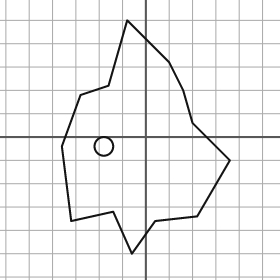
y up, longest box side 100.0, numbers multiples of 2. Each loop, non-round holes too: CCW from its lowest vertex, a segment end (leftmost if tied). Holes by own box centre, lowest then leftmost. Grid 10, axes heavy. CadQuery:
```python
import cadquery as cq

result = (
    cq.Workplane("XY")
    .moveTo(-6.0, -50.0)
    .lineTo(4.0, -36.0)
    .lineTo(22.0, -34.0)
    .lineTo(36.0, -10.0)
    .lineTo(20.0, 6.0)
    .lineTo(16.0, 20.0)
    .lineTo(10.0, 32.0)
    .lineTo(-8.0, 50.0)
    .lineTo(-16.0, 22.0)
    .lineTo(-28.0, 18.0)
    .lineTo(-36.0, -4.0)
    .lineTo(-32.0, -36.0)
    .lineTo(-14.0, -32.0)
    .close()
    .moveTo(-18.0, -4.0)
    .circle(4.0)
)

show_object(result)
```